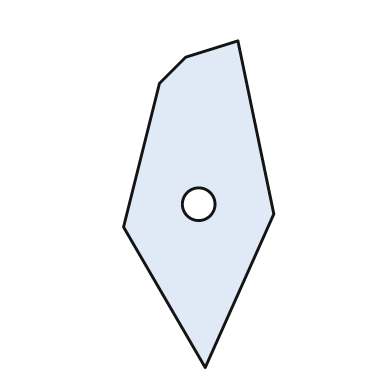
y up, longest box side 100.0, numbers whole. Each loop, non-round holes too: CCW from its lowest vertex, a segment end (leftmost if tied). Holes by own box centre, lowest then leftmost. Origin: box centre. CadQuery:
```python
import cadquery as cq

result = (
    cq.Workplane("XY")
    .moveTo(2.0, -50.0)
    .lineTo(23.0, -3.0)
    .lineTo(12.0, 50.0)
    .lineTo(-4.0, 45.0)
    .lineTo(-12.0, 37.0)
    .lineTo(-23.0, -7.0)
    .close()
    .moveTo(0.0, 0.0)
    .circle(5.0)
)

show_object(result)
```